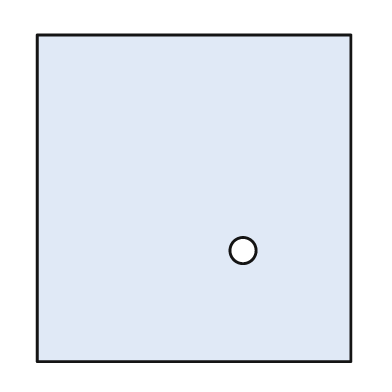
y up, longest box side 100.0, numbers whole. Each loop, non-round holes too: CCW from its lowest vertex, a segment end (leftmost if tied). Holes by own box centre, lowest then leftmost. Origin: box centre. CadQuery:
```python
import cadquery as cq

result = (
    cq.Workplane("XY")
    .moveTo(-48.0, -50.0)
    .lineTo(48.0, -50.0)
    .lineTo(48.0, 50.0)
    .lineTo(-48.0, 50.0)
    .close()
    .moveTo(15.0, -16.0)
    .circle(4.0)
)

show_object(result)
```